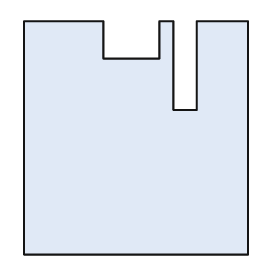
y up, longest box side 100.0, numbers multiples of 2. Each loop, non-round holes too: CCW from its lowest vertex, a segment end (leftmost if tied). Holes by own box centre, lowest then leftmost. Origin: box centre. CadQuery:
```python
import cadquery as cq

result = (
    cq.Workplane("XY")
    .moveTo(-48.0, -50.0)
    .lineTo(48.0, -50.0)
    .lineTo(48.0, 50.0)
    .lineTo(26.0, 50.0)
    .lineTo(26.0, 12.0)
    .lineTo(16.0, 12.0)
    .lineTo(16.0, 50.0)
    .lineTo(10.0, 50.0)
    .lineTo(10.0, 34.0)
    .lineTo(-14.0, 34.0)
    .lineTo(-14.0, 50.0)
    .lineTo(-48.0, 50.0)
    .close()
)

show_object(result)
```